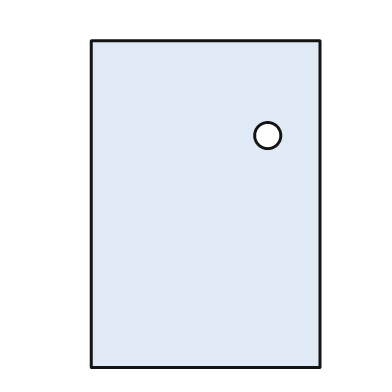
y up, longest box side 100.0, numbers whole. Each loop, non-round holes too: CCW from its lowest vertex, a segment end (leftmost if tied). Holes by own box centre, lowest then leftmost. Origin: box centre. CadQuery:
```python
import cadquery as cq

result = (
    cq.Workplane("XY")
    .moveTo(-35.0, -50.0)
    .lineTo(35.0, -50.0)
    .lineTo(35.0, 50.0)
    .lineTo(-35.0, 50.0)
    .close()
    .moveTo(19.0, 21.0)
    .circle(4.0)
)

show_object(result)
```